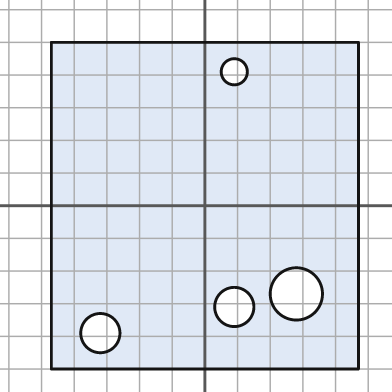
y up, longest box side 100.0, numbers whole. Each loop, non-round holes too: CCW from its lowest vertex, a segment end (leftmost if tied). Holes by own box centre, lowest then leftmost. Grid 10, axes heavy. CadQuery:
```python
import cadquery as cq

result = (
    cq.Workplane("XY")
    .moveTo(-47.0, -50.0)
    .lineTo(47.0, -50.0)
    .lineTo(47.0, 50.0)
    .lineTo(-47.0, 50.0)
    .close()
    .moveTo(-32.0, -39.0)
    .circle(6.0)
    .moveTo(9.0, -31.0)
    .circle(6.0)
    .moveTo(28.0, -27.0)
    .circle(8.0)
    .moveTo(9.0, 41.0)
    .circle(4.0)
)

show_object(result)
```